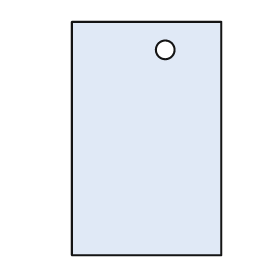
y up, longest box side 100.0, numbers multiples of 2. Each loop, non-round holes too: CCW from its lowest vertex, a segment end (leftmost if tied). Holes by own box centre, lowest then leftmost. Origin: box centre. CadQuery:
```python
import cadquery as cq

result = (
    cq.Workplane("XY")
    .moveTo(-32.0, -50.0)
    .lineTo(32.0, -50.0)
    .lineTo(32.0, 50.0)
    .lineTo(-32.0, 50.0)
    .close()
    .moveTo(8.0, 38.0)
    .circle(4.0)
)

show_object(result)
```